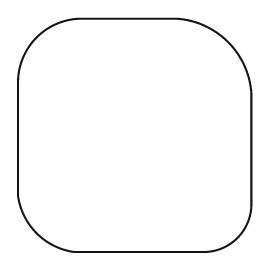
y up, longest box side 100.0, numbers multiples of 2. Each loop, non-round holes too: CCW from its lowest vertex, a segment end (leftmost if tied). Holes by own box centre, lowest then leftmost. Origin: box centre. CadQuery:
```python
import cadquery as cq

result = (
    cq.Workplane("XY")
    .moveTo(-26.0, -50.0)
    .lineTo(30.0, -50.0)
    .threePointArc((44.0, -44.0), (50.0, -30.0))
    .lineTo(50.0, 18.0)
    .threePointArc((40.0, 40.0), (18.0, 50.0))
    .lineTo(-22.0, 50.0)
    .threePointArc((-42.0, 42.0), (-50.0, 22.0))
    .lineTo(-50.0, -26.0)
    .threePointArc((-42.0, -42.0), (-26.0, -50.0))
    .close()
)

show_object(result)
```